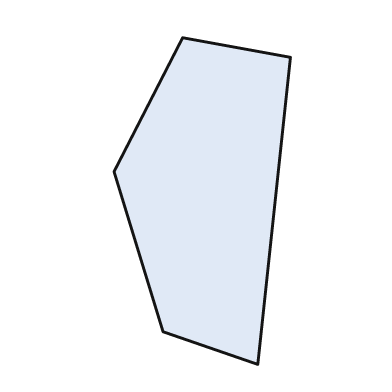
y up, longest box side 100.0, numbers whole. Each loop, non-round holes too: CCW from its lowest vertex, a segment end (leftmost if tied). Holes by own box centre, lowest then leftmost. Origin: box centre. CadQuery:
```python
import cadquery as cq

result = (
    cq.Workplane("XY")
    .moveTo(17.0, -50.0)
    .lineTo(27.0, 44.0)
    .lineTo(-6.0, 50.0)
    .lineTo(-27.0, 9.0)
    .lineTo(-12.0, -40.0)
    .close()
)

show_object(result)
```